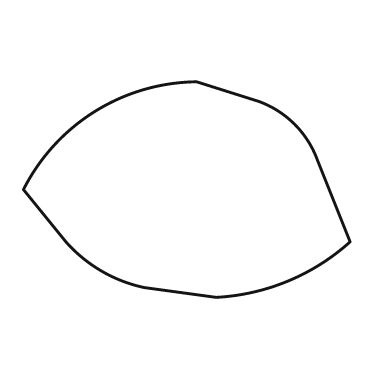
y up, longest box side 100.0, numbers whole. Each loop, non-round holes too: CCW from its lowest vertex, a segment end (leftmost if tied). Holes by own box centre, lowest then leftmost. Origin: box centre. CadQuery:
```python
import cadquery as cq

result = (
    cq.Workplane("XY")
    .moveTo(9.0, -33.0)
    .threePointArc((31.0, -28.0), (50.0, -16.0))
    .lineTo(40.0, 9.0)
    .threePointArc((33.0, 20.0), (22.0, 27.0))
    .lineTo(3.0, 33.0)
    .threePointArc((-28.0, 24.0), (-50.0, 0.0))
    .lineTo(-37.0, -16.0)
    .threePointArc((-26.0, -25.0), (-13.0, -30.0))
    .close()
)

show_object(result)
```